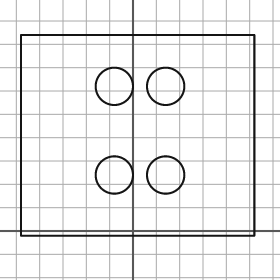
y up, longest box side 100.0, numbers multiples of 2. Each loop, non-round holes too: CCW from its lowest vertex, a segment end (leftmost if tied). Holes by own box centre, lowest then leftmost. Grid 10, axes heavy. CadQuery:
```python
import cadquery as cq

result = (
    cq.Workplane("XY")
    .moveTo(-48.0, -2.0)
    .lineTo(52.0, -2.0)
    .lineTo(52.0, 84.0)
    .lineTo(-48.0, 84.0)
    .close()
    .moveTo(-8.0, 24.0)
    .circle(8.0)
    .moveTo(14.0, 24.0)
    .circle(8.0)
    .moveTo(-8.0, 62.0)
    .circle(8.0)
    .moveTo(14.0, 62.0)
    .circle(8.0)
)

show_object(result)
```